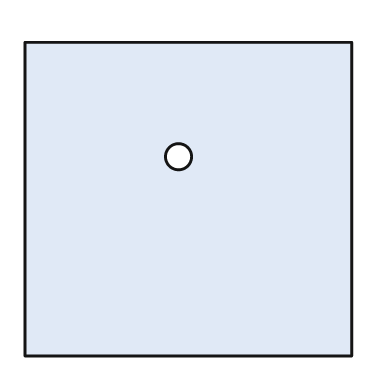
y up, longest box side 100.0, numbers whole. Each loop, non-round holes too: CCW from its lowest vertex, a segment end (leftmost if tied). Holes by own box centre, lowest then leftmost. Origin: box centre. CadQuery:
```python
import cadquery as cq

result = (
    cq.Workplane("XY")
    .moveTo(-50.0, -48.0)
    .lineTo(50.0, -48.0)
    .lineTo(50.0, 48.0)
    .lineTo(-50.0, 48.0)
    .close()
    .moveTo(-3.0, 13.0)
    .circle(4.0)
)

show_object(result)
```